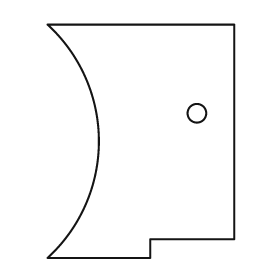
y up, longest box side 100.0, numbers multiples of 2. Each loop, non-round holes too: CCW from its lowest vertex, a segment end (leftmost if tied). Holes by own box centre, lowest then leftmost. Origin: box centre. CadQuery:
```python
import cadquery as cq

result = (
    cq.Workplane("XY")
    .moveTo(-40.0, -50.0)
    .lineTo(4.0, -50.0)
    .lineTo(4.0, -42.0)
    .lineTo(40.0, -42.0)
    .lineTo(40.0, 50.0)
    .lineTo(-40.0, 50.0)
    .threePointArc((-18.0, 0.0), (-40.0, -50.0))
    .close()
    .moveTo(24.0, 12.0)
    .circle(4.0)
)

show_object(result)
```